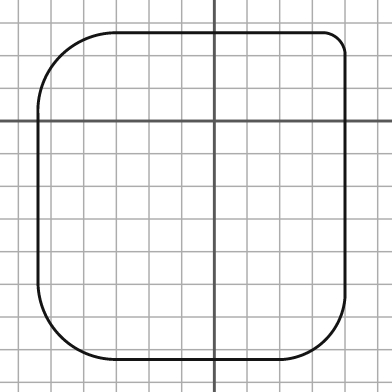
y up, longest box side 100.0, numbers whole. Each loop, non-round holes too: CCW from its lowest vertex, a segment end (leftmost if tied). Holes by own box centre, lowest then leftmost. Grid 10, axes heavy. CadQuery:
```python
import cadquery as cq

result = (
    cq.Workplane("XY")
    .moveTo(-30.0, -73.0)
    .lineTo(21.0, -73.0)
    .threePointArc((34.0, -67.0), (40.0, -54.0))
    .lineTo(40.0, 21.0)
    .threePointArc((38.0, 25.0), (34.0, 27.0))
    .lineTo(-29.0, 27.0)
    .threePointArc((-47.0, 20.0), (-54.0, 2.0))
    .lineTo(-54.0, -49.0)
    .threePointArc((-47.0, -66.0), (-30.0, -73.0))
    .close()
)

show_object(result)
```